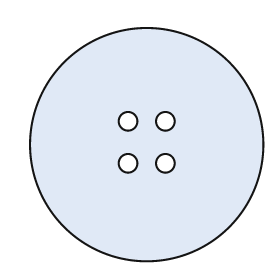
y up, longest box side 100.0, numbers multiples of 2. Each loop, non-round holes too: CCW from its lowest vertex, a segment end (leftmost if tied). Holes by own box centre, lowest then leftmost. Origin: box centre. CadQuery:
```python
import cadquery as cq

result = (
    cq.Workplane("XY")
    .moveTo(0.0, 0.0)
    .circle(50.0)
    .moveTo(-8.0, -8.0)
    .circle(4.0)
    .moveTo(8.0, -8.0)
    .circle(4.0)
    .moveTo(-8.0, 10.0)
    .circle(4.0)
    .moveTo(8.0, 10.0)
    .circle(4.0)
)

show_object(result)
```